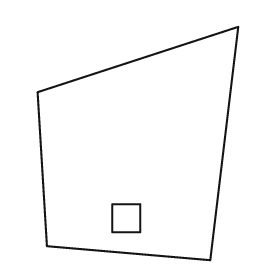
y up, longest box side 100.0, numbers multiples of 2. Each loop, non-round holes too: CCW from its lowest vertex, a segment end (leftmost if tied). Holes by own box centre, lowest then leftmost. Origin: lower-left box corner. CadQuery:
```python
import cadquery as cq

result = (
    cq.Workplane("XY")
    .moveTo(74.0, 0.0)
    .lineTo(86.0, 100.0)
    .lineTo(0.0, 72.0)
    .lineTo(4.0, 6.0)
    .close()
    .moveTo(32.0, 12.0)
    .lineTo(44.0, 12.0)
    .lineTo(44.0, 24.0)
    .lineTo(32.0, 24.0)
    .close()
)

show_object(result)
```